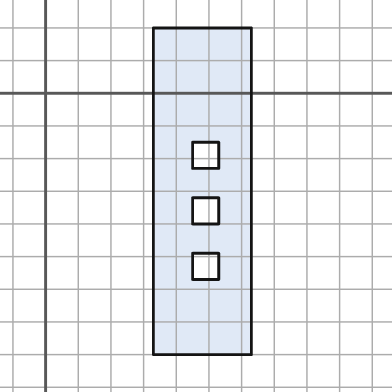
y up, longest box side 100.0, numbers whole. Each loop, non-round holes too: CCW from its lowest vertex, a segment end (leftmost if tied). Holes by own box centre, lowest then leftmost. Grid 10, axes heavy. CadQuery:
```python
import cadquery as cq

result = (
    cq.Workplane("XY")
    .moveTo(33.0, -80.0)
    .lineTo(63.0, -80.0)
    .lineTo(63.0, 20.0)
    .lineTo(33.0, 20.0)
    .close()
    .moveTo(45.0, -57.0)
    .lineTo(53.0, -57.0)
    .lineTo(53.0, -49.0)
    .lineTo(45.0, -49.0)
    .close()
    .moveTo(45.0, -40.0)
    .lineTo(53.0, -40.0)
    .lineTo(53.0, -32.0)
    .lineTo(45.0, -32.0)
    .close()
    .moveTo(45.0, -23.0)
    .lineTo(53.0, -23.0)
    .lineTo(53.0, -15.0)
    .lineTo(45.0, -15.0)
    .close()
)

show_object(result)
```